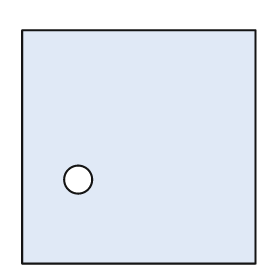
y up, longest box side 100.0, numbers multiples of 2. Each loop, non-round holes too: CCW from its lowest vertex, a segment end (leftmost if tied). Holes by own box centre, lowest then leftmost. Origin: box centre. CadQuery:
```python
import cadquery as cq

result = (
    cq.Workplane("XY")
    .moveTo(-50.0, -50.0)
    .lineTo(50.0, -50.0)
    .lineTo(50.0, 50.0)
    .lineTo(-50.0, 50.0)
    .close()
    .moveTo(-26.0, -14.0)
    .circle(6.0)
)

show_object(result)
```